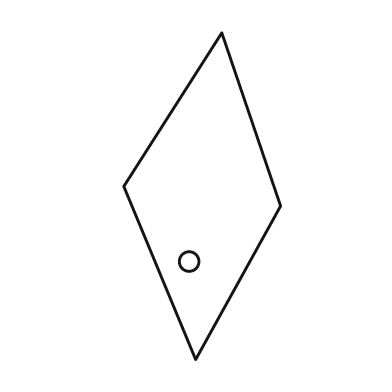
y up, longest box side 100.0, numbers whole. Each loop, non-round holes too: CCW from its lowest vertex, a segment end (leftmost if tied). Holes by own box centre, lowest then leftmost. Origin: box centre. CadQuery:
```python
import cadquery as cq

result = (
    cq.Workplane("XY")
    .moveTo(-2.0, -50.0)
    .lineTo(24.0, -3.0)
    .lineTo(6.0, 50.0)
    .lineTo(-24.0, 3.0)
    .close()
    .moveTo(-4.0, -20.0)
    .circle(3.0)
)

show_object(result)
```